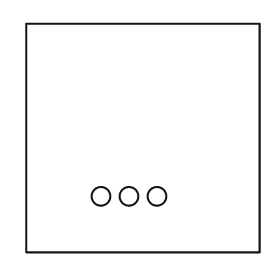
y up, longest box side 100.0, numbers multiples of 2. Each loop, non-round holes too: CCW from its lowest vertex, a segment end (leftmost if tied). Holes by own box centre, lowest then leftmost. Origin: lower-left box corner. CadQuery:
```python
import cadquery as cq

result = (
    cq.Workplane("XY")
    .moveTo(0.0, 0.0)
    .lineTo(100.0, 0.0)
    .lineTo(100.0, 98.0)
    .lineTo(0.0, 98.0)
    .close()
    .moveTo(32.0, 24.0)
    .circle(4.0)
    .moveTo(44.0, 24.0)
    .circle(4.0)
    .moveTo(56.0, 24.0)
    .circle(4.0)
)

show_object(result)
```